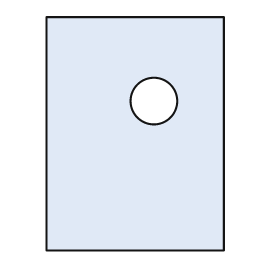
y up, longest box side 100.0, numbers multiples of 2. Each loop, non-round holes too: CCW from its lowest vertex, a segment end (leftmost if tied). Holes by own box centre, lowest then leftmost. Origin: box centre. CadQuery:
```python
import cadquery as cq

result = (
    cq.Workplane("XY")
    .moveTo(-38.0, -50.0)
    .lineTo(38.0, -50.0)
    .lineTo(38.0, 50.0)
    .lineTo(-38.0, 50.0)
    .close()
    .moveTo(8.0, 14.0)
    .circle(10.0)
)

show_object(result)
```